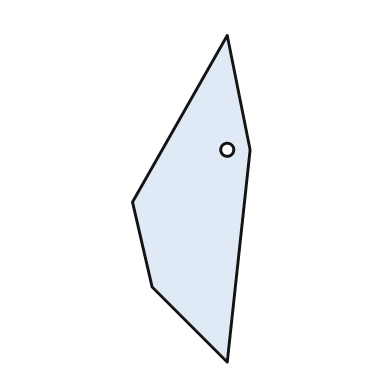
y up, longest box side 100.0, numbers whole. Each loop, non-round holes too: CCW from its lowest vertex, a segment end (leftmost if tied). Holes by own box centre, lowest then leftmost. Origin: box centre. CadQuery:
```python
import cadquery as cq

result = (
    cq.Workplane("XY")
    .moveTo(11.0, -50.0)
    .lineTo(18.0, 15.0)
    .lineTo(11.0, 50.0)
    .lineTo(-18.0, -1.0)
    .lineTo(-12.0, -27.0)
    .close()
    .moveTo(11.0, 15.0)
    .circle(2.0)
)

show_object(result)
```